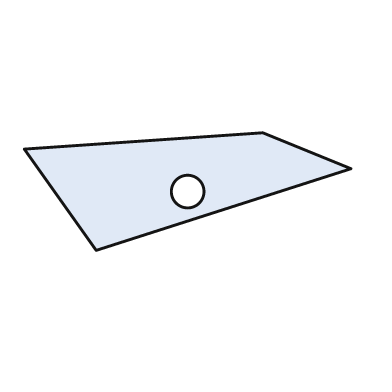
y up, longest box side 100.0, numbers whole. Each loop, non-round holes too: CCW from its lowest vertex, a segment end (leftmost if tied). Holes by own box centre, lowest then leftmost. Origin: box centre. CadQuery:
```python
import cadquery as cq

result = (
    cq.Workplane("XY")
    .moveTo(-28.0, -18.0)
    .lineTo(50.0, 7.0)
    .lineTo(23.0, 18.0)
    .lineTo(-50.0, 13.0)
    .close()
    .moveTo(0.0, 0.0)
    .circle(5.0)
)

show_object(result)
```